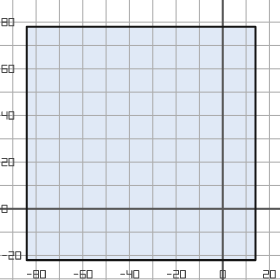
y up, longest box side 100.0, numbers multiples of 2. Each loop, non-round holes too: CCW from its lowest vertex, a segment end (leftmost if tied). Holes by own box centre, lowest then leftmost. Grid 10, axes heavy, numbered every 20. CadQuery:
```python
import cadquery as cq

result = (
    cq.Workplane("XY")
    .moveTo(-84.0, -22.0)
    .lineTo(14.0, -22.0)
    .lineTo(14.0, 78.0)
    .lineTo(-84.0, 78.0)
    .close()
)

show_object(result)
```